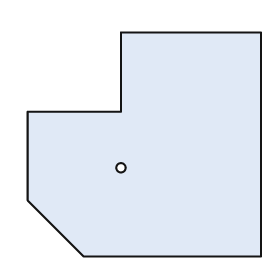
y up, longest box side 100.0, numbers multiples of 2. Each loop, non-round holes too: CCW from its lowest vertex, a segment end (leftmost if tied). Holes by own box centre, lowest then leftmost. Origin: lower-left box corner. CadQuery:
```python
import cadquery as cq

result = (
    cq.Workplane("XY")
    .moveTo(24.0, 0.0)
    .lineTo(100.0, 0.0)
    .lineTo(100.0, 96.0)
    .lineTo(40.0, 96.0)
    .lineTo(40.0, 62.0)
    .lineTo(0.0, 62.0)
    .lineTo(0.0, 24.0)
    .close()
    .moveTo(40.0, 38.0)
    .circle(2.0)
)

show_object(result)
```